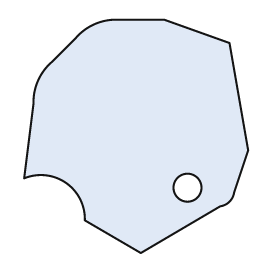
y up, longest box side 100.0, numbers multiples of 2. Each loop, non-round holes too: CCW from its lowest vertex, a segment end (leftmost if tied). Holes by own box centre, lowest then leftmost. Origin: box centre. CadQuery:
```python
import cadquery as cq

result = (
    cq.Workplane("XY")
    .moveTo(2.0, -50.0)
    .lineTo(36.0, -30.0)
    .threePointArc((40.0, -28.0), (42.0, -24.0))
    .lineTo(48.0, -6.0)
    .lineTo(40.0, 40.0)
    .lineTo(12.0, 50.0)
    .lineTo(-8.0, 50.0)
    .threePointArc((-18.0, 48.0), (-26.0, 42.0))
    .lineTo(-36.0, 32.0)
    .threePointArc((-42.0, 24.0), (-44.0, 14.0))
    .lineTo(-48.0, -18.0)
    .threePointArc((-30.0, -20.0), (-22.0, -36.0))
    .close()
    .moveTo(22.0, -22.0)
    .circle(6.0)
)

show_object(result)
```